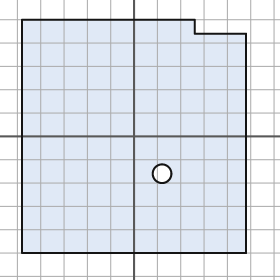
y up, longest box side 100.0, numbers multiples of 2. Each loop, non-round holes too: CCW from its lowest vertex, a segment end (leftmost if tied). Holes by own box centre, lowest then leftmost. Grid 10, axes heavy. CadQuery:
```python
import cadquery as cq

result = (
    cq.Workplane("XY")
    .moveTo(-48.0, -50.0)
    .lineTo(48.0, -50.0)
    .lineTo(48.0, 44.0)
    .lineTo(26.0, 44.0)
    .lineTo(26.0, 50.0)
    .lineTo(-48.0, 50.0)
    .close()
    .moveTo(12.0, -16.0)
    .circle(4.0)
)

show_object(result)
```